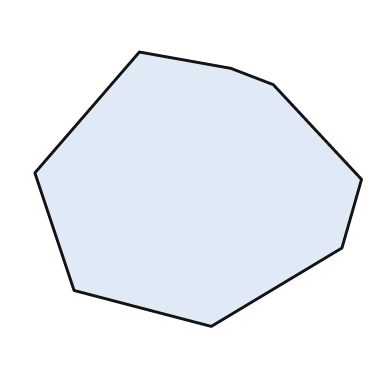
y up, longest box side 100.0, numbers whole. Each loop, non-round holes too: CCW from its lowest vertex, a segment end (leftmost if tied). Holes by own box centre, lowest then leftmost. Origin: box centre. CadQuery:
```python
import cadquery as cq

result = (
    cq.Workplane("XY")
    .moveTo(4.0, -42.0)
    .lineTo(44.0, -18.0)
    .lineTo(50.0, 3.0)
    .lineTo(23.0, 32.0)
    .lineTo(10.0, 37.0)
    .lineTo(-18.0, 42.0)
    .lineTo(-50.0, 5.0)
    .lineTo(-38.0, -31.0)
    .close()
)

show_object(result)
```